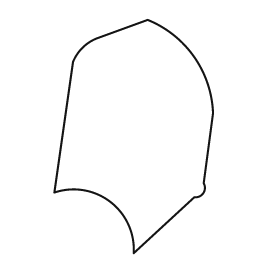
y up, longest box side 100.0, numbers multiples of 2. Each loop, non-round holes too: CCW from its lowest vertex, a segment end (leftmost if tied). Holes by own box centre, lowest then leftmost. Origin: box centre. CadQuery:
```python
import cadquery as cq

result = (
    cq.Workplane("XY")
    .moveTo(0.0, -50.0)
    .lineTo(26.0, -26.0)
    .threePointArc((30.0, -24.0), (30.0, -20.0))
    .lineTo(34.0, 10.0)
    .threePointArc((26.0, 34.0), (6.0, 50.0))
    .lineTo(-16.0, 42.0)
    .threePointArc((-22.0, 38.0), (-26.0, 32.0))
    .lineTo(-34.0, -24.0)
    .threePointArc((-10.0, -28.0), (0.0, -50.0))
    .close()
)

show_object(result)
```